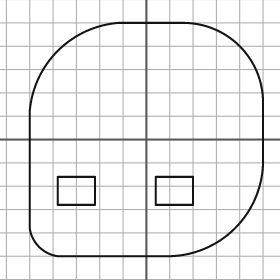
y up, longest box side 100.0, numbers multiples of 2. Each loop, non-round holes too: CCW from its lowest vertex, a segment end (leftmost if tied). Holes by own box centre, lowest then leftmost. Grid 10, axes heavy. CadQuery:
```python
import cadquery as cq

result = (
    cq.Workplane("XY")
    .moveTo(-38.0, -50.0)
    .lineTo(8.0, -50.0)
    .threePointArc((38.0, -38.0), (50.0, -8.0))
    .lineTo(50.0, 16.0)
    .threePointArc((40.0, 40.0), (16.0, 50.0))
    .lineTo(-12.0, 50.0)
    .threePointArc((-38.0, 38.0), (-50.0, 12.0))
    .lineTo(-50.0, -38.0)
    .threePointArc((-46.0, -46.0), (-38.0, -50.0))
    .close()
    .moveTo(-38.0, -28.0)
    .lineTo(-22.0, -28.0)
    .lineTo(-22.0, -16.0)
    .lineTo(-38.0, -16.0)
    .close()
    .moveTo(4.0, -28.0)
    .lineTo(20.0, -28.0)
    .lineTo(20.0, -16.0)
    .lineTo(4.0, -16.0)
    .close()
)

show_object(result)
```